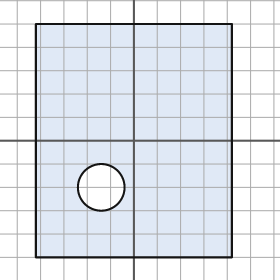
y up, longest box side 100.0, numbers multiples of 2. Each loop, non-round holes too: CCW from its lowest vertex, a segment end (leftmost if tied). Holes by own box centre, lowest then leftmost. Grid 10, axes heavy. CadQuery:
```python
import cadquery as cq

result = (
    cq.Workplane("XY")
    .moveTo(-42.0, -50.0)
    .lineTo(42.0, -50.0)
    .lineTo(42.0, 50.0)
    .lineTo(-42.0, 50.0)
    .close()
    .moveTo(-14.0, -20.0)
    .circle(10.0)
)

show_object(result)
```